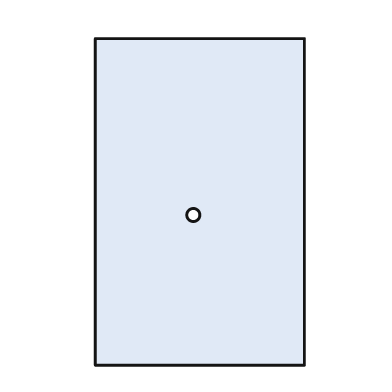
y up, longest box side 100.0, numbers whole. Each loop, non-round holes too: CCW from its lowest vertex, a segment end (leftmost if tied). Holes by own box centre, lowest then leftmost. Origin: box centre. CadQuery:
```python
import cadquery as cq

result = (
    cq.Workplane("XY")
    .moveTo(-32.0, -50.0)
    .lineTo(32.0, -50.0)
    .lineTo(32.0, 50.0)
    .lineTo(-32.0, 50.0)
    .close()
    .moveTo(-2.0, -4.0)
    .circle(2.0)
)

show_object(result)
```